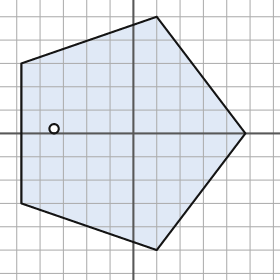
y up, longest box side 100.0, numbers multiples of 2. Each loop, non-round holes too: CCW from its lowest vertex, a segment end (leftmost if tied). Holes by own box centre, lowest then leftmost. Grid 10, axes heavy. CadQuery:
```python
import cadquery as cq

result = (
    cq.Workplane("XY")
    .moveTo(10.0, -50.0)
    .lineTo(48.0, 0.0)
    .lineTo(10.0, 50.0)
    .lineTo(-48.0, 30.0)
    .lineTo(-48.0, -30.0)
    .close()
    .moveTo(-34.0, 2.0)
    .circle(2.0)
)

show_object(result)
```